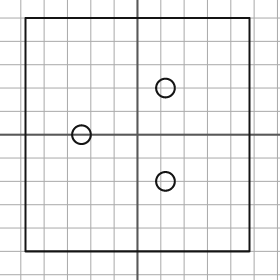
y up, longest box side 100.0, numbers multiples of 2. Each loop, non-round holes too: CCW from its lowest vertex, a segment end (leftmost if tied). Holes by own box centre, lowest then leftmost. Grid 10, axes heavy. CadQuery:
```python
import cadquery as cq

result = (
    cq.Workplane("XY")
    .moveTo(-48.0, -50.0)
    .lineTo(48.0, -50.0)
    .lineTo(48.0, 50.0)
    .lineTo(-48.0, 50.0)
    .close()
    .moveTo(12.0, -20.0)
    .circle(4.0)
    .moveTo(-24.0, 0.0)
    .circle(4.0)
    .moveTo(12.0, 20.0)
    .circle(4.0)
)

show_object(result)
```